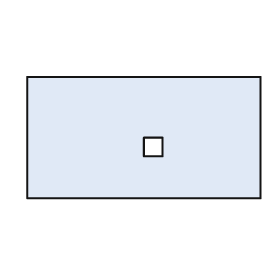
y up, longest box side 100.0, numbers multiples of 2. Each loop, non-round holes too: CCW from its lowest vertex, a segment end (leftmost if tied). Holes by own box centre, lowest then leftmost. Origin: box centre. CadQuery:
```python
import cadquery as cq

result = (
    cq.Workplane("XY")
    .moveTo(-50.0, -26.0)
    .lineTo(50.0, -26.0)
    .lineTo(50.0, 26.0)
    .lineTo(-50.0, 26.0)
    .close()
    .moveTo(0.0, -8.0)
    .lineTo(8.0, -8.0)
    .lineTo(8.0, 0.0)
    .lineTo(0.0, 0.0)
    .close()
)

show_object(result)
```